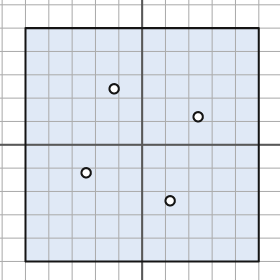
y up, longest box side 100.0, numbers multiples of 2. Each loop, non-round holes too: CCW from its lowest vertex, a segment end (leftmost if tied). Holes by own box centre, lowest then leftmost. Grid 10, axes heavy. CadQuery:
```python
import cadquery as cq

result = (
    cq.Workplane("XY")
    .moveTo(-50.0, -50.0)
    .lineTo(50.0, -50.0)
    .lineTo(50.0, 50.0)
    .lineTo(-50.0, 50.0)
    .close()
    .moveTo(12.0, -24.0)
    .circle(2.0)
    .moveTo(-24.0, -12.0)
    .circle(2.0)
    .moveTo(24.0, 12.0)
    .circle(2.0)
    .moveTo(-12.0, 24.0)
    .circle(2.0)
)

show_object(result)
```